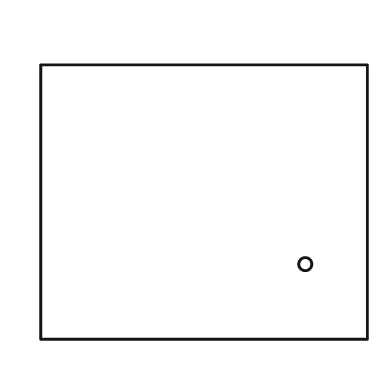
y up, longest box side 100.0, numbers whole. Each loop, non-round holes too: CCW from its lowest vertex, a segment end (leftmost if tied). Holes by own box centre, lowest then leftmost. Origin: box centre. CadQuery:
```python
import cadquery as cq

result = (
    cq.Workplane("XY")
    .moveTo(-50.0, -42.0)
    .lineTo(50.0, -42.0)
    .lineTo(50.0, 42.0)
    .lineTo(-50.0, 42.0)
    .close()
    .moveTo(31.0, -19.0)
    .circle(2.0)
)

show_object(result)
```